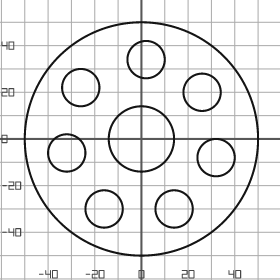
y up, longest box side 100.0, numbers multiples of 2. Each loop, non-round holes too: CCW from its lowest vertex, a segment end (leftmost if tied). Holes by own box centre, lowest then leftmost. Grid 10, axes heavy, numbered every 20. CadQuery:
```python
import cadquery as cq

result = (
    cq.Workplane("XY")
    .moveTo(0.0, 0.0)
    .circle(50.0)
    .moveTo(-16.0, -30.0)
    .circle(8.0)
    .moveTo(14.0, -30.0)
    .circle(8.0)
    .moveTo(32.0, -8.0)
    .circle(8.0)
    .moveTo(-32.0, -6.0)
    .circle(8.0)
    .moveTo(0.0, 0.0)
    .circle(14.0)
    .moveTo(26.0, 20.0)
    .circle(8.0)
    .moveTo(-26.0, 22.0)
    .circle(8.0)
    .moveTo(2.0, 34.0)
    .circle(8.0)
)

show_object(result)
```